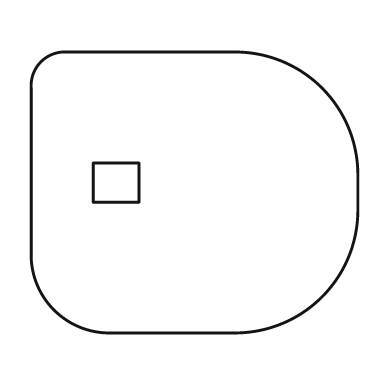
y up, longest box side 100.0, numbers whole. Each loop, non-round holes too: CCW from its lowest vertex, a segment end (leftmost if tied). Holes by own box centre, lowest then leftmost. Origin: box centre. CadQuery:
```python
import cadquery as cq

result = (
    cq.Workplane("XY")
    .moveTo(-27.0, -43.0)
    .lineTo(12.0, -43.0)
    .threePointArc((39.0, -32.0), (50.0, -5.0))
    .lineTo(50.0, 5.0)
    .threePointArc((39.0, 32.0), (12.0, 43.0))
    .lineTo(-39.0, 43.0)
    .threePointArc((-47.0, 40.0), (-50.0, 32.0))
    .lineTo(-50.0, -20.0)
    .threePointArc((-43.0, -36.0), (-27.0, -43.0))
    .close()
    .moveTo(-31.0, -3.0)
    .lineTo(-17.0, -3.0)
    .lineTo(-17.0, 9.0)
    .lineTo(-31.0, 9.0)
    .close()
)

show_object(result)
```